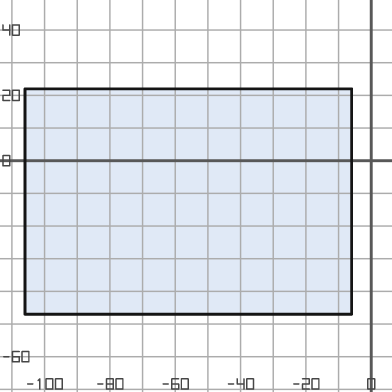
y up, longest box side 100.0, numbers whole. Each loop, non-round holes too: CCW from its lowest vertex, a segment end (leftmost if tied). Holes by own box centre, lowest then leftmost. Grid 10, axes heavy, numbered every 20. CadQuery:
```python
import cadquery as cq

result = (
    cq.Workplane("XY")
    .moveTo(-106.0, -47.0)
    .lineTo(-6.0, -47.0)
    .lineTo(-6.0, 22.0)
    .lineTo(-106.0, 22.0)
    .close()
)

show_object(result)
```